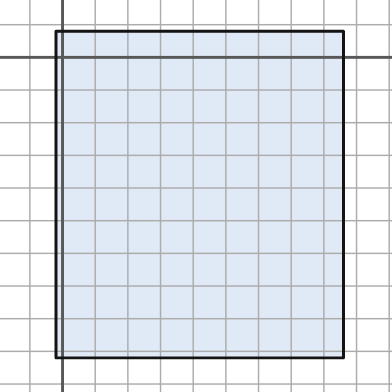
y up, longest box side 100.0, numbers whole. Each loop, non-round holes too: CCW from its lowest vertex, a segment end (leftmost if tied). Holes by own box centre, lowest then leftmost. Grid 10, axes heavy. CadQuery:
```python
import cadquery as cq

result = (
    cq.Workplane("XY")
    .moveTo(-2.0, -92.0)
    .lineTo(86.0, -92.0)
    .lineTo(86.0, 8.0)
    .lineTo(-2.0, 8.0)
    .close()
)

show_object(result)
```